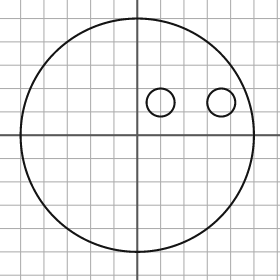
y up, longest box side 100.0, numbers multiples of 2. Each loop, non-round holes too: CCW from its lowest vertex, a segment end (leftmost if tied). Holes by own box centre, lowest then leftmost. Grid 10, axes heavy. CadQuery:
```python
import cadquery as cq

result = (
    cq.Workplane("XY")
    .moveTo(0.0, 0.0)
    .circle(50.0)
    .moveTo(10.0, 14.0)
    .circle(6.0)
    .moveTo(36.0, 14.0)
    .circle(6.0)
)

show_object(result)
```